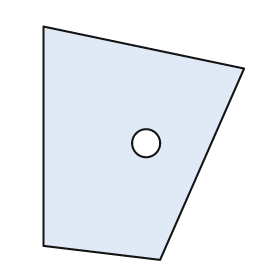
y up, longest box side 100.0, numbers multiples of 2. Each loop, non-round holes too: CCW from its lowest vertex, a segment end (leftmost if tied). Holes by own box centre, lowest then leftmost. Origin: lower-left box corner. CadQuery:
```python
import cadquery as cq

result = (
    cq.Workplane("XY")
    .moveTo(50.0, 0.0)
    .lineTo(86.0, 82.0)
    .lineTo(0.0, 100.0)
    .lineTo(0.0, 6.0)
    .close()
    .moveTo(44.0, 50.0)
    .circle(6.0)
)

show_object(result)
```